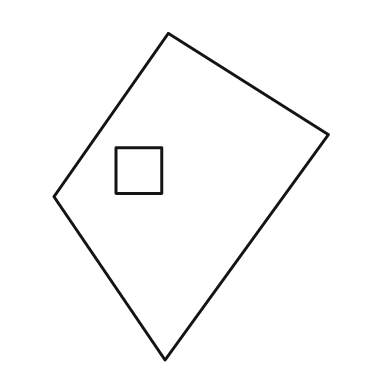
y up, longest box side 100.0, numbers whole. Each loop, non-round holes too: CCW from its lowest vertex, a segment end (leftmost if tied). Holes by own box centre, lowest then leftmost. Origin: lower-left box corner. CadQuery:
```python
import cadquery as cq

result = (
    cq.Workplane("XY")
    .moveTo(34.0, 0.0)
    .lineTo(84.0, 69.0)
    .lineTo(35.0, 100.0)
    .lineTo(0.0, 50.0)
    .close()
    .moveTo(19.0, 51.0)
    .lineTo(33.0, 51.0)
    .lineTo(33.0, 65.0)
    .lineTo(19.0, 65.0)
    .close()
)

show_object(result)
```